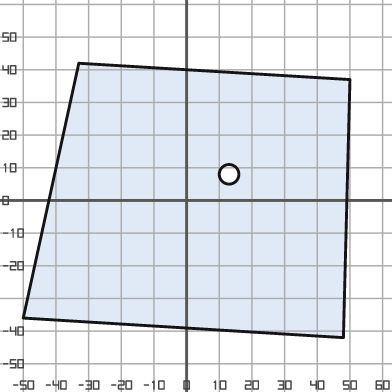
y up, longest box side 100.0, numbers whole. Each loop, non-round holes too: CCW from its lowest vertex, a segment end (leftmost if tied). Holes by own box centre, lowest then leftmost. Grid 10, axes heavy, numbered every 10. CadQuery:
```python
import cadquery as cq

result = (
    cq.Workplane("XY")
    .moveTo(48.0, -42.0)
    .lineTo(50.0, 37.0)
    .lineTo(-33.0, 42.0)
    .lineTo(-50.0, -36.0)
    .close()
    .moveTo(13.0, 8.0)
    .circle(3.0)
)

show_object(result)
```